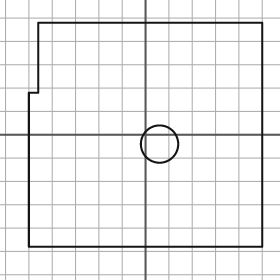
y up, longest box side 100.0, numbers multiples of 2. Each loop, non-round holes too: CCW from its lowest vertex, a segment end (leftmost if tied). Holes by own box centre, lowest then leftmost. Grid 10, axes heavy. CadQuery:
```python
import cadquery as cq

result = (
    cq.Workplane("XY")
    .moveTo(-50.0, -48.0)
    .lineTo(50.0, -48.0)
    .lineTo(50.0, 48.0)
    .lineTo(-46.0, 48.0)
    .lineTo(-46.0, 18.0)
    .lineTo(-50.0, 18.0)
    .close()
    .moveTo(6.0, -4.0)
    .circle(8.0)
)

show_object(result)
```